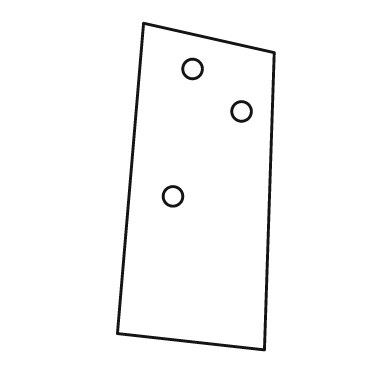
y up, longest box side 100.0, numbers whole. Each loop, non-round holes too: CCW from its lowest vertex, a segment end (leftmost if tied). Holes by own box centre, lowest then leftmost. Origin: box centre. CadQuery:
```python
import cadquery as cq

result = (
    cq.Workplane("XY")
    .moveTo(21.0, -50.0)
    .lineTo(24.0, 41.0)
    .lineTo(-16.0, 50.0)
    .lineTo(-24.0, -45.0)
    .close()
    .moveTo(-7.0, -3.0)
    .circle(3.0)
    .moveTo(14.0, 23.0)
    .circle(3.0)
    .moveTo(-1.0, 36.0)
    .circle(3.0)
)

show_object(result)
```